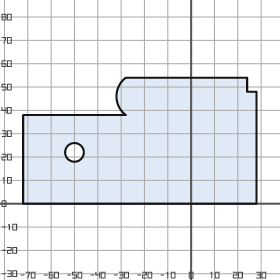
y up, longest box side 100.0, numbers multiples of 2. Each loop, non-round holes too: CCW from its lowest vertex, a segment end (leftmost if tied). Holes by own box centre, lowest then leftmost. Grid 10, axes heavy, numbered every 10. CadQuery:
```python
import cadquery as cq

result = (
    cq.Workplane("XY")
    .moveTo(-72.0, 0.0)
    .lineTo(28.0, 0.0)
    .lineTo(28.0, 48.0)
    .lineTo(24.0, 48.0)
    .lineTo(24.0, 54.0)
    .lineTo(-28.0, 54.0)
    .threePointArc((-32.0, 46.0), (-28.0, 38.0))
    .lineTo(-72.0, 38.0)
    .close()
    .moveTo(-50.0, 22.0)
    .circle(4.0)
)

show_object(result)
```